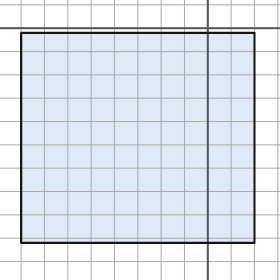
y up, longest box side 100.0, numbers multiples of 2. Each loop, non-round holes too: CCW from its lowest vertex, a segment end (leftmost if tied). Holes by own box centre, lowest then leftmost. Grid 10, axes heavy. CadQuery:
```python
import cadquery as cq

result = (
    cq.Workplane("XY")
    .moveTo(-80.0, -92.0)
    .lineTo(20.0, -92.0)
    .lineTo(20.0, -2.0)
    .lineTo(-80.0, -2.0)
    .close()
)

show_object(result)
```